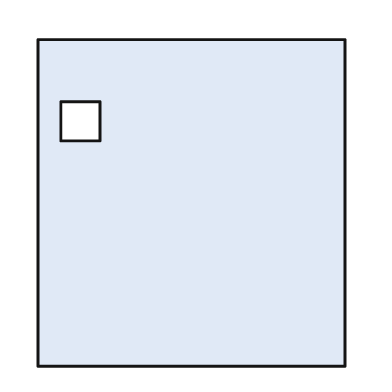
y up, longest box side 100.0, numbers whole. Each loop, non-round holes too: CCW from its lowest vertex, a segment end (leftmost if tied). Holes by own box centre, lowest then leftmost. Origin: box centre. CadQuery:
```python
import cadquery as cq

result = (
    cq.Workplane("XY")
    .moveTo(-47.0, -50.0)
    .lineTo(47.0, -50.0)
    .lineTo(47.0, 50.0)
    .lineTo(-47.0, 50.0)
    .close()
    .moveTo(-40.0, 19.0)
    .lineTo(-28.0, 19.0)
    .lineTo(-28.0, 31.0)
    .lineTo(-40.0, 31.0)
    .close()
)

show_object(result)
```